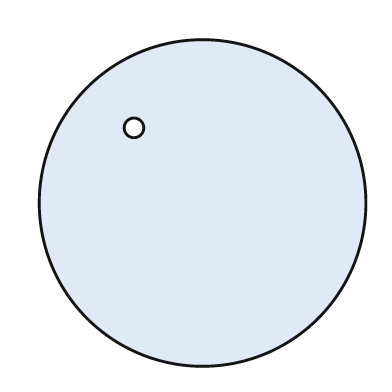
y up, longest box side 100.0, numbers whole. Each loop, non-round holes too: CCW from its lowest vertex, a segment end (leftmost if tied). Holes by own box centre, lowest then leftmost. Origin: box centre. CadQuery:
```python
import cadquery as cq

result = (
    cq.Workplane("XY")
    .moveTo(0.0, 0.0)
    .circle(50.0)
    .moveTo(-21.0, 23.0)
    .circle(3.0)
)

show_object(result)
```